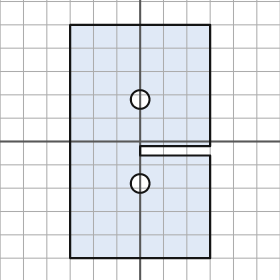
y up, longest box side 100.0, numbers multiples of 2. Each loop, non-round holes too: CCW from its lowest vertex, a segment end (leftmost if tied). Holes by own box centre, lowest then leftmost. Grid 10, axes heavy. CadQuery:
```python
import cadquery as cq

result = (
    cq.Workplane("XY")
    .moveTo(-30.0, -50.0)
    .lineTo(30.0, -50.0)
    .lineTo(30.0, -6.0)
    .lineTo(0.0, -6.0)
    .lineTo(0.0, -2.0)
    .lineTo(30.0, -2.0)
    .lineTo(30.0, 50.0)
    .lineTo(-30.0, 50.0)
    .close()
    .moveTo(0.0, -18.0)
    .circle(4.0)
    .moveTo(0.0, 18.0)
    .circle(4.0)
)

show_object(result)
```